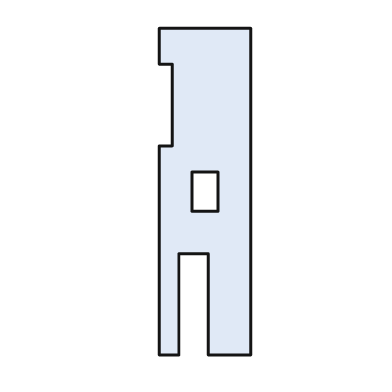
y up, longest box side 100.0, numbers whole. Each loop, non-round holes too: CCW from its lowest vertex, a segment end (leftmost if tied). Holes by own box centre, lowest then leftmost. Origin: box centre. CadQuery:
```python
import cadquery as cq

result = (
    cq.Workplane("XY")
    .moveTo(-14.0, -50.0)
    .lineTo(-8.0, -50.0)
    .lineTo(-8.0, -19.0)
    .lineTo(1.0, -19.0)
    .lineTo(1.0, -50.0)
    .lineTo(14.0, -50.0)
    .lineTo(14.0, 50.0)
    .lineTo(-14.0, 50.0)
    .lineTo(-14.0, 39.0)
    .lineTo(-10.0, 39.0)
    .lineTo(-10.0, 14.0)
    .lineTo(-14.0, 14.0)
    .close()
    .moveTo(-4.0, -6.0)
    .lineTo(4.0, -6.0)
    .lineTo(4.0, 6.0)
    .lineTo(-4.0, 6.0)
    .close()
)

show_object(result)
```